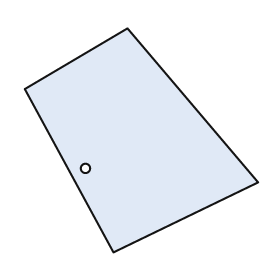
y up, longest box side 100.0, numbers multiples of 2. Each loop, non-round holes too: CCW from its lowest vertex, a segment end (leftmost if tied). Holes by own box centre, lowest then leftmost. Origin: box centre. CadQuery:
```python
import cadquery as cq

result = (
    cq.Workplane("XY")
    .moveTo(-12.0, -48.0)
    .lineTo(50.0, -18.0)
    .lineTo(-6.0, 48.0)
    .lineTo(-50.0, 22.0)
    .close()
    .moveTo(-24.0, -12.0)
    .circle(2.0)
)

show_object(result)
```